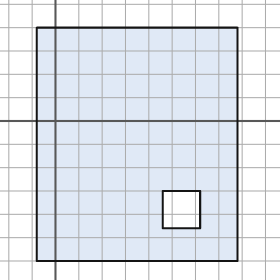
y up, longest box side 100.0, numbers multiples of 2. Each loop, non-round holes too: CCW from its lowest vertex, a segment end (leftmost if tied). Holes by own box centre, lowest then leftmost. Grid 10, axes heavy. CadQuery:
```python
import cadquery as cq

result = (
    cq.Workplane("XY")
    .moveTo(-8.0, -60.0)
    .lineTo(78.0, -60.0)
    .lineTo(78.0, 40.0)
    .lineTo(-8.0, 40.0)
    .close()
    .moveTo(46.0, -46.0)
    .lineTo(62.0, -46.0)
    .lineTo(62.0, -30.0)
    .lineTo(46.0, -30.0)
    .close()
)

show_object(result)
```